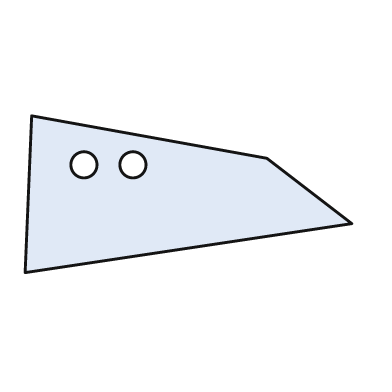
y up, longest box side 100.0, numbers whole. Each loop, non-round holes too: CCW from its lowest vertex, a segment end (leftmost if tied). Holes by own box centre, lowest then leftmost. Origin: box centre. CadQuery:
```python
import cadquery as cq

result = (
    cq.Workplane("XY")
    .moveTo(-50.0, -24.0)
    .lineTo(50.0, -9.0)
    .lineTo(24.0, 11.0)
    .lineTo(-48.0, 24.0)
    .close()
    .moveTo(-32.0, 9.0)
    .circle(4.0)
    .moveTo(-17.0, 9.0)
    .circle(4.0)
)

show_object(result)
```